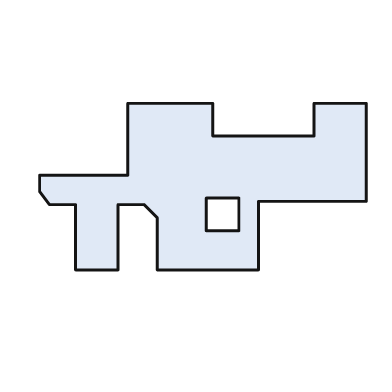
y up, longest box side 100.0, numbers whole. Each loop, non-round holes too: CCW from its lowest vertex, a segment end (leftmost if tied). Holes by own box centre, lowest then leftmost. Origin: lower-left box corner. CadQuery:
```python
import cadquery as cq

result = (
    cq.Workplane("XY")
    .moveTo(11.0, 0.0)
    .lineTo(24.0, 0.0)
    .lineTo(24.0, 20.0)
    .lineTo(32.0, 20.0)
    .lineTo(36.0, 16.0)
    .lineTo(36.0, 0.0)
    .lineTo(67.0, 0.0)
    .lineTo(67.0, 21.0)
    .lineTo(100.0, 21.0)
    .lineTo(100.0, 51.0)
    .lineTo(84.0, 51.0)
    .lineTo(84.0, 41.0)
    .lineTo(53.0, 41.0)
    .lineTo(53.0, 51.0)
    .lineTo(27.0, 51.0)
    .lineTo(27.0, 29.0)
    .lineTo(0.0, 29.0)
    .lineTo(0.0, 24.0)
    .lineTo(3.0, 20.0)
    .lineTo(11.0, 20.0)
    .close()
    .moveTo(51.0, 12.0)
    .lineTo(61.0, 12.0)
    .lineTo(61.0, 22.0)
    .lineTo(51.0, 22.0)
    .close()
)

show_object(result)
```